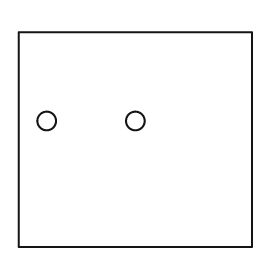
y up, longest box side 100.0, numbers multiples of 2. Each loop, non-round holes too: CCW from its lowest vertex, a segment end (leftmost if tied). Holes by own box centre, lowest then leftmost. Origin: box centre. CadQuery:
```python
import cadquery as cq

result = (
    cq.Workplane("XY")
    .moveTo(-50.0, -46.0)
    .lineTo(50.0, -46.0)
    .lineTo(50.0, 46.0)
    .lineTo(-50.0, 46.0)
    .close()
    .moveTo(-38.0, 8.0)
    .circle(4.0)
    .moveTo(0.0, 8.0)
    .circle(4.0)
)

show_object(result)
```